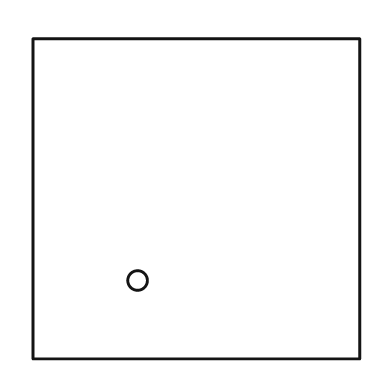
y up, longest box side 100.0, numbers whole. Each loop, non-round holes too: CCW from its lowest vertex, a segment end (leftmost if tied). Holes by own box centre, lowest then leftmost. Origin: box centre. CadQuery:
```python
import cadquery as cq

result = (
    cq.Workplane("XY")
    .moveTo(-50.0, -49.0)
    .lineTo(50.0, -49.0)
    .lineTo(50.0, 49.0)
    .lineTo(-50.0, 49.0)
    .close()
    .moveTo(-18.0, -25.0)
    .circle(3.0)
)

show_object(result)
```